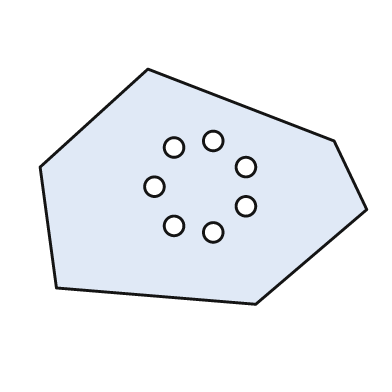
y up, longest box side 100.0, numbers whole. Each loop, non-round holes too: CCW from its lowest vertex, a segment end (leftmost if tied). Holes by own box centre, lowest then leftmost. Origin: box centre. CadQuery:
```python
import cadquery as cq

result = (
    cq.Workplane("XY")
    .moveTo(16.0, -36.0)
    .lineTo(50.0, -7.0)
    .lineTo(40.0, 14.0)
    .lineTo(-17.0, 36.0)
    .lineTo(-50.0, 6.0)
    .lineTo(-45.0, -31.0)
    .close()
    .moveTo(3.0, -14.0)
    .circle(3.0)
    .moveTo(-9.0, -12.0)
    .circle(3.0)
    .moveTo(13.0, -6.0)
    .circle(3.0)
    .moveTo(-15.0, 0.0)
    .circle(3.0)
    .moveTo(13.0, 6.0)
    .circle(3.0)
    .moveTo(-9.0, 12.0)
    .circle(3.0)
    .moveTo(3.0, 14.0)
    .circle(3.0)
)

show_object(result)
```